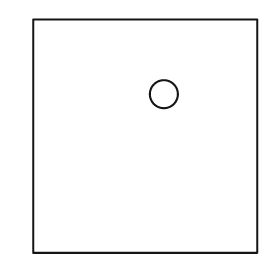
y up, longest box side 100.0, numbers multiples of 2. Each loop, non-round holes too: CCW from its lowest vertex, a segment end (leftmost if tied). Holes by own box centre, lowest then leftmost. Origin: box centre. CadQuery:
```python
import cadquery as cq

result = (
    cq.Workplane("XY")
    .moveTo(-48.0, -50.0)
    .lineTo(48.0, -50.0)
    .lineTo(48.0, 50.0)
    .lineTo(-48.0, 50.0)
    .close()
    .moveTo(8.0, 18.0)
    .circle(6.0)
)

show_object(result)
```